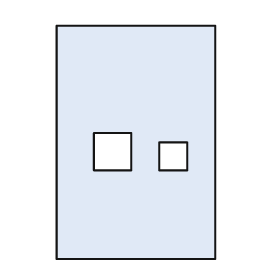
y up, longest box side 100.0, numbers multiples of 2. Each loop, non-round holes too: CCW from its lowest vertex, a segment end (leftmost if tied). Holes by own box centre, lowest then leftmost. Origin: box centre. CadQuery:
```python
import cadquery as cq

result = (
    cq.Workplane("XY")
    .moveTo(-34.0, -50.0)
    .lineTo(34.0, -50.0)
    .lineTo(34.0, 50.0)
    .lineTo(-34.0, 50.0)
    .close()
    .moveTo(10.0, -12.0)
    .lineTo(22.0, -12.0)
    .lineTo(22.0, 0.0)
    .lineTo(10.0, 0.0)
    .close()
    .moveTo(-18.0, -12.0)
    .lineTo(-2.0, -12.0)
    .lineTo(-2.0, 4.0)
    .lineTo(-18.0, 4.0)
    .close()
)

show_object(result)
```